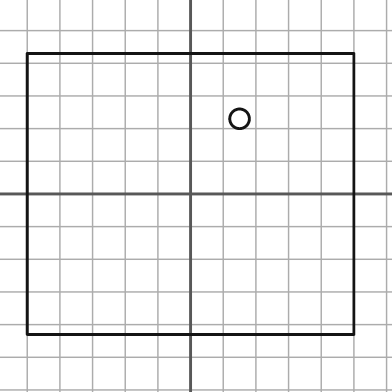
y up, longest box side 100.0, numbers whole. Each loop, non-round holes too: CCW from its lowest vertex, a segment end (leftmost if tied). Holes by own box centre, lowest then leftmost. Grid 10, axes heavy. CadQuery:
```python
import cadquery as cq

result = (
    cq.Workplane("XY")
    .moveTo(-50.0, -43.0)
    .lineTo(50.0, -43.0)
    .lineTo(50.0, 43.0)
    .lineTo(-50.0, 43.0)
    .close()
    .moveTo(15.0, 23.0)
    .circle(3.0)
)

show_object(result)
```